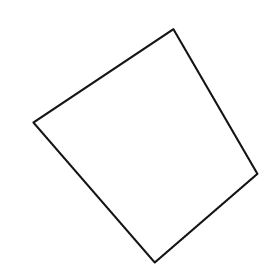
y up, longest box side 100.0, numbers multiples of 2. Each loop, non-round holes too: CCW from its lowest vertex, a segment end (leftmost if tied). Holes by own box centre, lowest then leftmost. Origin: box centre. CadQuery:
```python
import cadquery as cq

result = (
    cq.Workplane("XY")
    .moveTo(4.0, -50.0)
    .lineTo(48.0, -12.0)
    .lineTo(12.0, 50.0)
    .lineTo(-48.0, 10.0)
    .close()
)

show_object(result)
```